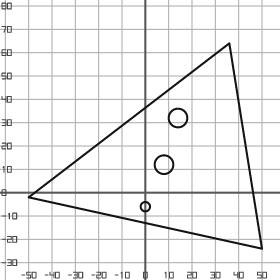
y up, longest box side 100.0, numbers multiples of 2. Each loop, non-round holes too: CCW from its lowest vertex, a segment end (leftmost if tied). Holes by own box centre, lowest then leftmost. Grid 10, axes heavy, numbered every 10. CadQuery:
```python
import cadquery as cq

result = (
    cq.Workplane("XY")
    .moveTo(50.0, -24.0)
    .lineTo(36.0, 64.0)
    .lineTo(-50.0, -2.0)
    .close()
    .moveTo(0.0, -6.0)
    .circle(2.0)
    .moveTo(8.0, 12.0)
    .circle(4.0)
    .moveTo(14.0, 32.0)
    .circle(4.0)
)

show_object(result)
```